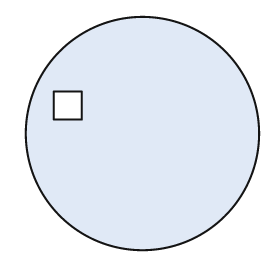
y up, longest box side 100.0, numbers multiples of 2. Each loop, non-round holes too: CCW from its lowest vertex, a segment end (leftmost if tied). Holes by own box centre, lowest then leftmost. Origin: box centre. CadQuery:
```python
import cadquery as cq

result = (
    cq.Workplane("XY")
    .moveTo(0.0, 0.0)
    .circle(50.0)
    .moveTo(-38.0, 6.0)
    .lineTo(-26.0, 6.0)
    .lineTo(-26.0, 18.0)
    .lineTo(-38.0, 18.0)
    .close()
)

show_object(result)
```